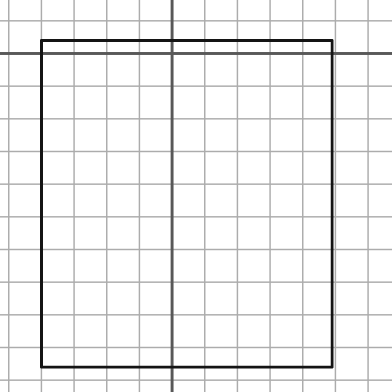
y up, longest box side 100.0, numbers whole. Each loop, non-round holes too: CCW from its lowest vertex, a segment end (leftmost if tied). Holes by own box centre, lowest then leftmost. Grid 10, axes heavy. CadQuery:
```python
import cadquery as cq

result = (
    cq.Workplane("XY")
    .moveTo(-40.0, -96.0)
    .lineTo(49.0, -96.0)
    .lineTo(49.0, 4.0)
    .lineTo(-40.0, 4.0)
    .close()
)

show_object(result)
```